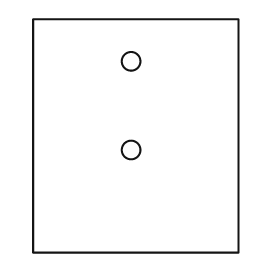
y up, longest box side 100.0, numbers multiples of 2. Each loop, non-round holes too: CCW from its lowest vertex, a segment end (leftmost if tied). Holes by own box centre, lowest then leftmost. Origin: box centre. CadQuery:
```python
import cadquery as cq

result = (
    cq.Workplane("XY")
    .moveTo(-44.0, -50.0)
    .lineTo(44.0, -50.0)
    .lineTo(44.0, 50.0)
    .lineTo(-44.0, 50.0)
    .close()
    .moveTo(-2.0, -6.0)
    .circle(4.0)
    .moveTo(-2.0, 32.0)
    .circle(4.0)
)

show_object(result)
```